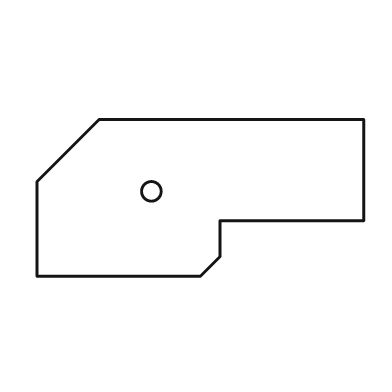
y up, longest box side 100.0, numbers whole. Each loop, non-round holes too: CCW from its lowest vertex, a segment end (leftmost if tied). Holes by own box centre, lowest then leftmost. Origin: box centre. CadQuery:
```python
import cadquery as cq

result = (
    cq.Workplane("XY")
    .moveTo(-50.0, -24.0)
    .lineTo(0.0, -24.0)
    .lineTo(6.0, -18.0)
    .lineTo(6.0, -7.0)
    .lineTo(50.0, -7.0)
    .lineTo(50.0, 24.0)
    .lineTo(-31.0, 24.0)
    .lineTo(-50.0, 5.0)
    .close()
    .moveTo(-15.0, 2.0)
    .circle(3.0)
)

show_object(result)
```